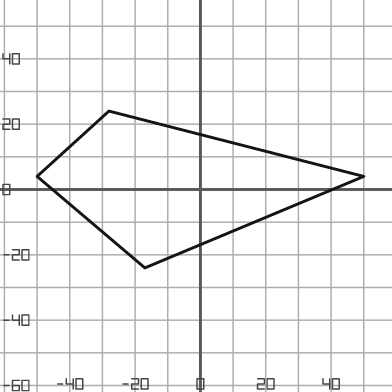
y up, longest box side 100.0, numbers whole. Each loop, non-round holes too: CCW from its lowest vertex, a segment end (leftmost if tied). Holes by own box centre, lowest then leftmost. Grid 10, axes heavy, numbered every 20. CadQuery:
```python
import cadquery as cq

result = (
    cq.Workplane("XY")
    .moveTo(-17.0, -24.0)
    .lineTo(50.0, 4.0)
    .lineTo(-28.0, 24.0)
    .lineTo(-50.0, 4.0)
    .close()
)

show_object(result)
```